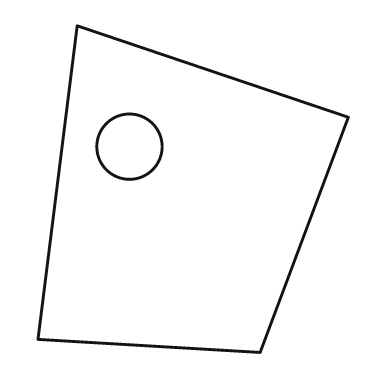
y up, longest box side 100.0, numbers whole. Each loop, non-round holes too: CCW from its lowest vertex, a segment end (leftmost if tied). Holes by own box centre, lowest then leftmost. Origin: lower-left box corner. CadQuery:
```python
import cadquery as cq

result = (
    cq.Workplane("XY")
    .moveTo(68.0, 0.0)
    .lineTo(95.0, 72.0)
    .lineTo(12.0, 100.0)
    .lineTo(0.0, 4.0)
    .close()
    .moveTo(28.0, 63.0)
    .circle(10.0)
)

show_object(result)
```